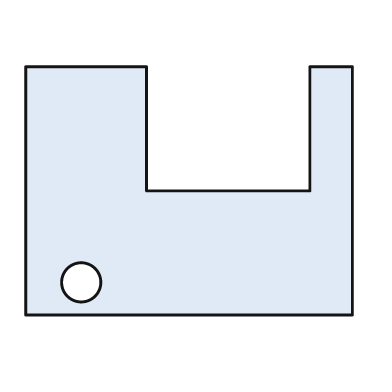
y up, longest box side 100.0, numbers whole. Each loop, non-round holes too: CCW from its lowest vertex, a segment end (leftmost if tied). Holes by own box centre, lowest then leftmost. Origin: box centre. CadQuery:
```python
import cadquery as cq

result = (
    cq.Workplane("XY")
    .moveTo(-50.0, -38.0)
    .lineTo(50.0, -38.0)
    .lineTo(50.0, 38.0)
    .lineTo(37.0, 38.0)
    .lineTo(37.0, 0.0)
    .lineTo(-13.0, 0.0)
    .lineTo(-13.0, 38.0)
    .lineTo(-50.0, 38.0)
    .close()
    .moveTo(-33.0, -28.0)
    .circle(6.0)
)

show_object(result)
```